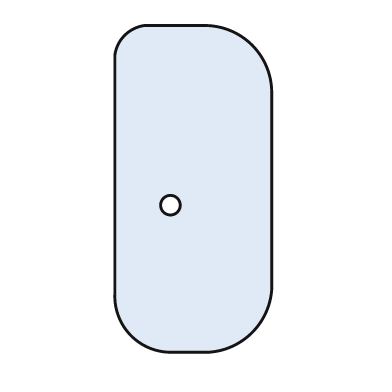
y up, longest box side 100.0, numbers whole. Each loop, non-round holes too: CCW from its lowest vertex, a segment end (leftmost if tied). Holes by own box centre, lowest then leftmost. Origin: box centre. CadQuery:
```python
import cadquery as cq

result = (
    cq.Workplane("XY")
    .moveTo(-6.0, -50.0)
    .lineTo(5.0, -50.0)
    .threePointArc((18.0, -44.0), (24.0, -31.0))
    .lineTo(24.0, 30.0)
    .threePointArc((18.0, 44.0), (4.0, 50.0))
    .lineTo(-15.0, 50.0)
    .threePointArc((-21.0, 47.0), (-24.0, 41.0))
    .lineTo(-24.0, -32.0)
    .threePointArc((-19.0, -45.0), (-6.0, -50.0))
    .close()
    .moveTo(-7.0, -5.0)
    .circle(3.0)
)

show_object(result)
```